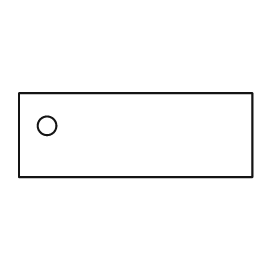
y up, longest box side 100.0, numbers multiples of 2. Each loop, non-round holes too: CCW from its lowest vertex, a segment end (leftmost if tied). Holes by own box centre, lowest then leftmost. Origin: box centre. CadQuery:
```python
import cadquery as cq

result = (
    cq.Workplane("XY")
    .moveTo(-50.0, -18.0)
    .lineTo(50.0, -18.0)
    .lineTo(50.0, 18.0)
    .lineTo(-50.0, 18.0)
    .close()
    .moveTo(-38.0, 4.0)
    .circle(4.0)
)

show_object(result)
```